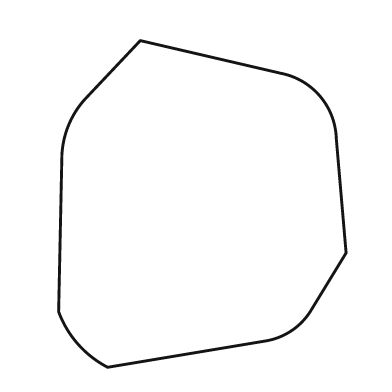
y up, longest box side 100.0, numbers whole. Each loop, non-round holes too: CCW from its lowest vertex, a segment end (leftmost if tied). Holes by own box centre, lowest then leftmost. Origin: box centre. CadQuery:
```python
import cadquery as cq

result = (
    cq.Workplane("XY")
    .moveTo(-29.0, -50.0)
    .lineTo(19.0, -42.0)
    .threePointArc((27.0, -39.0), (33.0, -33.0))
    .lineTo(44.0, -15.0)
    .lineTo(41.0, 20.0)
    .threePointArc((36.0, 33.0), (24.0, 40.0))
    .lineTo(-19.0, 50.0)
    .lineTo(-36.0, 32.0)
    .threePointArc((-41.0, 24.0), (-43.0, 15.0))
    .lineTo(-44.0, -33.0)
    .threePointArc((-38.0, -43.0), (-29.0, -50.0))
    .close()
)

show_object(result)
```